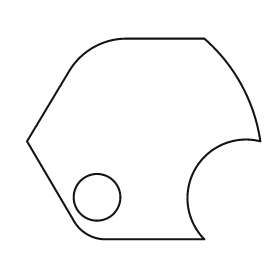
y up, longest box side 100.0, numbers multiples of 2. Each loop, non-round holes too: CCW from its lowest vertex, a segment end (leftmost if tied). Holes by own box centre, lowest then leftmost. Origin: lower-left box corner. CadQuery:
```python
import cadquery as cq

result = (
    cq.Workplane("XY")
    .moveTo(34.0, 0.0)
    .lineTo(76.0, 0.0)
    .threePointArc((72.0, 30.0), (100.0, 42.0))
    .threePointArc((92.0, 66.0), (76.0, 86.0))
    .lineTo(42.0, 86.0)
    .threePointArc((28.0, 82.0), (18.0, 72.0))
    .lineTo(0.0, 42.0)
    .lineTo(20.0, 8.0)
    .threePointArc((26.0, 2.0), (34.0, 0.0))
    .close()
    .moveTo(30.0, 18.0)
    .circle(10.0)
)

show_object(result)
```